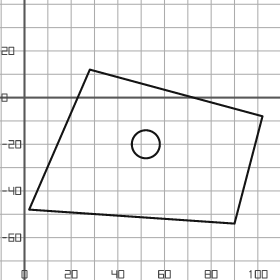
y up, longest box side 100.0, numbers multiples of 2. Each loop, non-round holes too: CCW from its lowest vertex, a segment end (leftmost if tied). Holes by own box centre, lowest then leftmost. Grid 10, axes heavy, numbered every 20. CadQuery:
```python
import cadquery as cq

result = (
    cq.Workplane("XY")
    .moveTo(90.0, -54.0)
    .lineTo(102.0, -8.0)
    .lineTo(28.0, 12.0)
    .lineTo(2.0, -48.0)
    .close()
    .moveTo(52.0, -20.0)
    .circle(6.0)
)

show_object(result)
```